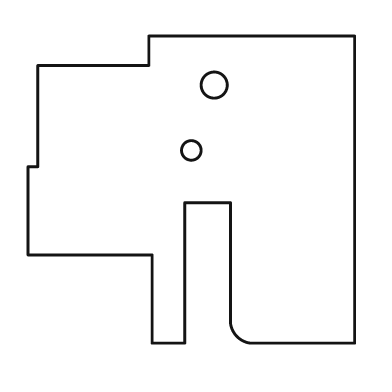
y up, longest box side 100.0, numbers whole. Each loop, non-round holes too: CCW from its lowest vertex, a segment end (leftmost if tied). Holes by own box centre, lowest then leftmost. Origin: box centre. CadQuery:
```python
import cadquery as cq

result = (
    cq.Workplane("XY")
    .moveTo(-12.0, -47.0)
    .lineTo(-2.0, -47.0)
    .lineTo(-2.0, -4.0)
    .lineTo(12.0, -4.0)
    .lineTo(12.0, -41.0)
    .threePointArc((14.0, -45.0), (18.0, -47.0))
    .lineTo(50.0, -47.0)
    .lineTo(50.0, 47.0)
    .lineTo(-13.0, 47.0)
    .lineTo(-13.0, 38.0)
    .lineTo(-47.0, 38.0)
    .lineTo(-47.0, 7.0)
    .lineTo(-50.0, 7.0)
    .lineTo(-50.0, -20.0)
    .lineTo(-12.0, -20.0)
    .close()
    .moveTo(0.0, 12.0)
    .circle(3.0)
    .moveTo(7.0, 32.0)
    .circle(4.0)
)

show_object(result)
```